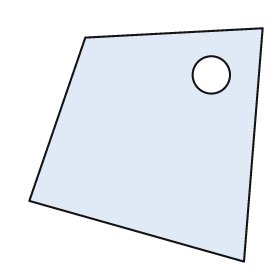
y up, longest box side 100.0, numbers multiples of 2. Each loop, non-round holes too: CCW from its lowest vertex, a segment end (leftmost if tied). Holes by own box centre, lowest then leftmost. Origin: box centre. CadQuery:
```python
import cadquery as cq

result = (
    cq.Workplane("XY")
    .moveTo(42.0, -50.0)
    .lineTo(50.0, 50.0)
    .lineTo(-26.0, 46.0)
    .lineTo(-50.0, -24.0)
    .close()
    .moveTo(28.0, 30.0)
    .circle(8.0)
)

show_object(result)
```